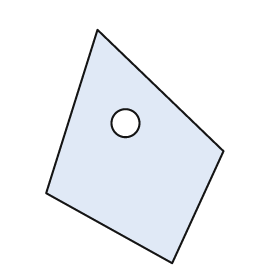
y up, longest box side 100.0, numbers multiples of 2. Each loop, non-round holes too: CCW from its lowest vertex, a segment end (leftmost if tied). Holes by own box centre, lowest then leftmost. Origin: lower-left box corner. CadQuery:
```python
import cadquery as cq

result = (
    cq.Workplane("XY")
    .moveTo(54.0, 0.0)
    .lineTo(76.0, 48.0)
    .lineTo(22.0, 100.0)
    .lineTo(0.0, 30.0)
    .close()
    .moveTo(34.0, 60.0)
    .circle(6.0)
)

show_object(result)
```